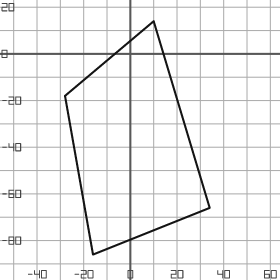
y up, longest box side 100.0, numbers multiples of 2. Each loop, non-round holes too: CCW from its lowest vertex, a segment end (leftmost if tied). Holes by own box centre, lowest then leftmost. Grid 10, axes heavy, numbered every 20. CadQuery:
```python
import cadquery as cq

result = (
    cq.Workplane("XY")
    .moveTo(-16.0, -86.0)
    .lineTo(34.0, -66.0)
    .lineTo(10.0, 14.0)
    .lineTo(-28.0, -18.0)
    .close()
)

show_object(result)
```